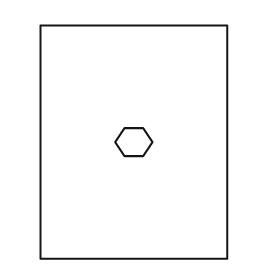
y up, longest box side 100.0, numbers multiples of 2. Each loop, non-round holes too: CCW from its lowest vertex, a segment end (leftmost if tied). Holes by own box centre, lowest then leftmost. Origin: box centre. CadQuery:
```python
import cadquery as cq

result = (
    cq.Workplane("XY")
    .moveTo(-40.0, -50.0)
    .lineTo(40.0, -50.0)
    .lineTo(40.0, 50.0)
    .lineTo(-40.0, 50.0)
    .close()
    .moveTo(-4.0, -6.0)
    .lineTo(4.0, -6.0)
    .lineTo(8.0, 0.0)
    .lineTo(4.0, 6.0)
    .lineTo(-4.0, 6.0)
    .lineTo(-8.0, 0.0)
    .close()
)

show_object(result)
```